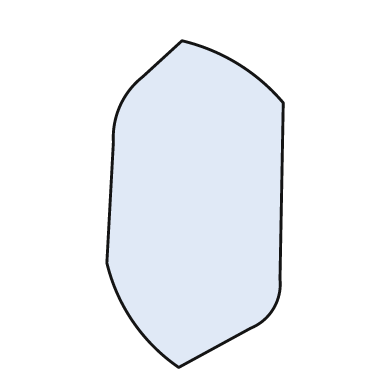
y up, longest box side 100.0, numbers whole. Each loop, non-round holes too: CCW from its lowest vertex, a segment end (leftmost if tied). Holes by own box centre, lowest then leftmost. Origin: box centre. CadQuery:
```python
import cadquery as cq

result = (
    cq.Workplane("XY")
    .moveTo(-5.0, -50.0)
    .lineTo(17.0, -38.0)
    .threePointArc((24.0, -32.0), (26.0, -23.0))
    .lineTo(27.0, 31.0)
    .threePointArc((13.0, 43.0), (-4.0, 50.0))
    .lineTo(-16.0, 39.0)
    .threePointArc((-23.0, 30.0), (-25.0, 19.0))
    .lineTo(-27.0, -18.0)
    .threePointArc((-19.0, -36.0), (-5.0, -50.0))
    .close()
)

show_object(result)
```